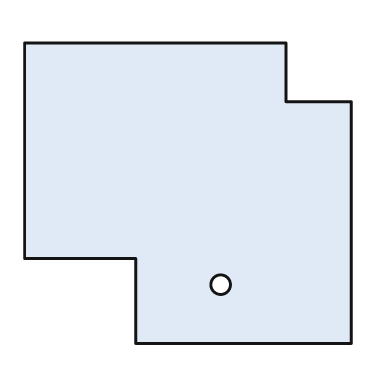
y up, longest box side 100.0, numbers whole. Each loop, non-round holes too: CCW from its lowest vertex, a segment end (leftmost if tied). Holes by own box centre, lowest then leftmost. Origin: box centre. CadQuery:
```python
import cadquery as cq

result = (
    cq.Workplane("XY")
    .moveTo(-16.0, -46.0)
    .lineTo(50.0, -46.0)
    .lineTo(50.0, 28.0)
    .lineTo(30.0, 28.0)
    .lineTo(30.0, 46.0)
    .lineTo(-50.0, 46.0)
    .lineTo(-50.0, -20.0)
    .lineTo(-16.0, -20.0)
    .close()
    .moveTo(10.0, -28.0)
    .circle(3.0)
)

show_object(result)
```